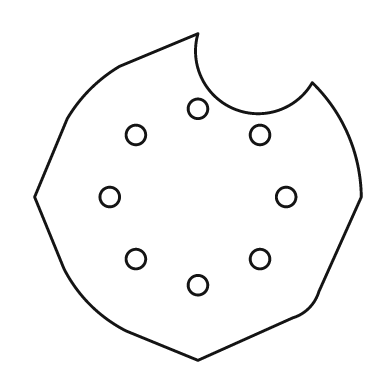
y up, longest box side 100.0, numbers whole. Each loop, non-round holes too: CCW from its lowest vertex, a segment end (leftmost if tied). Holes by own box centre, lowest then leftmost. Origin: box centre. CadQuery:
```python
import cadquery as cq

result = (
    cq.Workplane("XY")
    .moveTo(0.0, -50.0)
    .lineTo(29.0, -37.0)
    .threePointArc((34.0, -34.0), (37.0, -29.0))
    .lineTo(50.0, 0.0)
    .threePointArc((46.0, 19.0), (35.0, 35.0))
    .threePointArc((11.0, 27.0), (0.0, 50.0))
    .lineTo(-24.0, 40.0)
    .threePointArc((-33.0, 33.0), (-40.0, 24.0))
    .lineTo(-50.0, 0.0)
    .lineTo(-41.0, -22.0)
    .threePointArc((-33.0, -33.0), (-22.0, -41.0))
    .close()
    .moveTo(0.0, -27.0)
    .circle(3.0)
    .moveTo(-19.0, -19.0)
    .circle(3.0)
    .moveTo(19.0, -19.0)
    .circle(3.0)
    .moveTo(-27.0, 0.0)
    .circle(3.0)
    .moveTo(27.0, 0.0)
    .circle(3.0)
    .moveTo(-19.0, 19.0)
    .circle(3.0)
    .moveTo(19.0, 19.0)
    .circle(3.0)
    .moveTo(0.0, 27.0)
    .circle(3.0)
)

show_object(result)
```